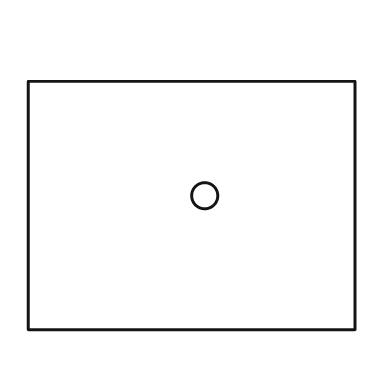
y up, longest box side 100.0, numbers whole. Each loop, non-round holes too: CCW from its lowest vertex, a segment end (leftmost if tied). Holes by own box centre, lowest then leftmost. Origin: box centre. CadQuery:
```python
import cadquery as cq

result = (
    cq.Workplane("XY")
    .moveTo(-50.0, -38.0)
    .lineTo(50.0, -38.0)
    .lineTo(50.0, 38.0)
    .lineTo(-50.0, 38.0)
    .close()
    .moveTo(4.0, 3.0)
    .circle(4.0)
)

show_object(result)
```